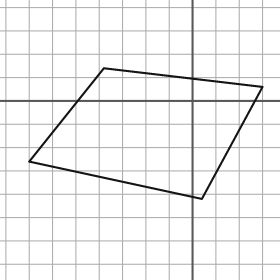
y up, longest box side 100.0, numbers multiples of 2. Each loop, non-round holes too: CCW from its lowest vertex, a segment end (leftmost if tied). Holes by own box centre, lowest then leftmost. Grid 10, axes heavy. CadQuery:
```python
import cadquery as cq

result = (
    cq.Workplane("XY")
    .moveTo(4.0, -42.0)
    .lineTo(30.0, 6.0)
    .lineTo(-38.0, 14.0)
    .lineTo(-70.0, -26.0)
    .close()
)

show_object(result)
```